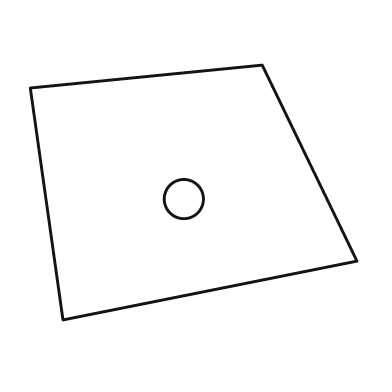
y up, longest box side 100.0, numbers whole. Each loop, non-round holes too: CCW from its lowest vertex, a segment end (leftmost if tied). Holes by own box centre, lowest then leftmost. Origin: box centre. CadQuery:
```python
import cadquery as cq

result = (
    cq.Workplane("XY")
    .moveTo(-40.0, -39.0)
    .lineTo(50.0, -21.0)
    .lineTo(21.0, 39.0)
    .lineTo(-50.0, 32.0)
    .close()
    .moveTo(-3.0, -2.0)
    .circle(6.0)
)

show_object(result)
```